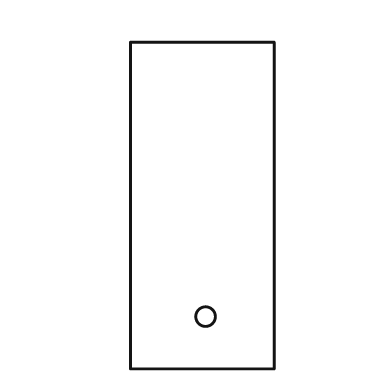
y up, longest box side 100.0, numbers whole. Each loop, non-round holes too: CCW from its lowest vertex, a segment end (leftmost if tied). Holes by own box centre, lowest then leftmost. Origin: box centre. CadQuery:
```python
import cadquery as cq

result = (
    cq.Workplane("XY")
    .moveTo(-22.0, -50.0)
    .lineTo(22.0, -50.0)
    .lineTo(22.0, 50.0)
    .lineTo(-22.0, 50.0)
    .close()
    .moveTo(1.0, -34.0)
    .circle(3.0)
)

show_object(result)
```